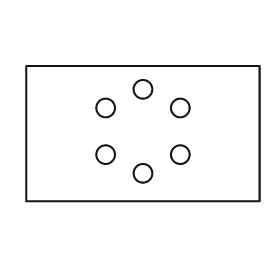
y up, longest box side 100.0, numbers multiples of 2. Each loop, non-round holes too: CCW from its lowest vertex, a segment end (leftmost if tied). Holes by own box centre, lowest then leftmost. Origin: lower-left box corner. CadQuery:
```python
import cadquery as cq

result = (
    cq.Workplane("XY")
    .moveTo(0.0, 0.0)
    .lineTo(100.0, 0.0)
    .lineTo(100.0, 58.0)
    .lineTo(0.0, 58.0)
    .close()
    .moveTo(50.0, 12.0)
    .circle(4.0)
    .moveTo(34.0, 20.0)
    .circle(4.0)
    .moveTo(66.0, 20.0)
    .circle(4.0)
    .moveTo(34.0, 40.0)
    .circle(4.0)
    .moveTo(66.0, 40.0)
    .circle(4.0)
    .moveTo(50.0, 48.0)
    .circle(4.0)
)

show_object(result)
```